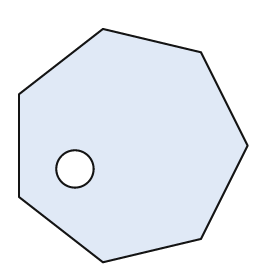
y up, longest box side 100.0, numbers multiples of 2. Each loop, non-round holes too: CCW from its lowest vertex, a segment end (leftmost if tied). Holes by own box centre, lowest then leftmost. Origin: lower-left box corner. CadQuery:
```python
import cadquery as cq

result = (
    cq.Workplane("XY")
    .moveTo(36.0, 0.0)
    .lineTo(78.0, 10.0)
    .lineTo(98.0, 50.0)
    .lineTo(78.0, 90.0)
    .lineTo(36.0, 100.0)
    .lineTo(0.0, 72.0)
    .lineTo(0.0, 28.0)
    .close()
    .moveTo(24.0, 40.0)
    .circle(8.0)
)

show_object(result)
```